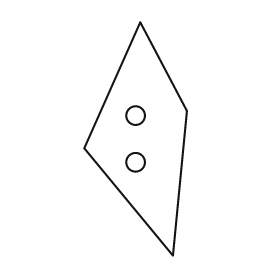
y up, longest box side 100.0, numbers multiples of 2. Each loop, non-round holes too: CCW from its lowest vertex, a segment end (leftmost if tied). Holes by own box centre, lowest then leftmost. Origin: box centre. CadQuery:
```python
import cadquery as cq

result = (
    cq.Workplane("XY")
    .moveTo(16.0, -50.0)
    .lineTo(22.0, 12.0)
    .lineTo(2.0, 50.0)
    .lineTo(-22.0, -4.0)
    .close()
    .moveTo(0.0, -10.0)
    .circle(4.0)
    .moveTo(0.0, 10.0)
    .circle(4.0)
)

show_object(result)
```